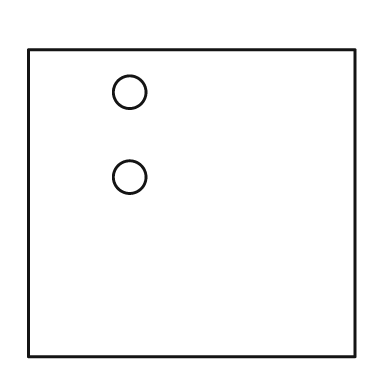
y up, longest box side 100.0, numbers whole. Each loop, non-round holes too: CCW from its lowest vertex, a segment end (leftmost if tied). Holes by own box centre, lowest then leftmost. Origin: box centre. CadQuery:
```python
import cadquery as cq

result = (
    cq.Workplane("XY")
    .moveTo(-50.0, -47.0)
    .lineTo(50.0, -47.0)
    .lineTo(50.0, 47.0)
    .lineTo(-50.0, 47.0)
    .close()
    .moveTo(-19.0, 8.0)
    .circle(5.0)
    .moveTo(-19.0, 34.0)
    .circle(5.0)
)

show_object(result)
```